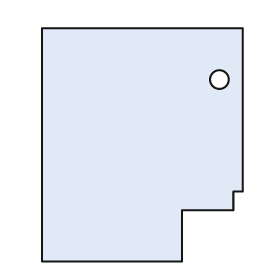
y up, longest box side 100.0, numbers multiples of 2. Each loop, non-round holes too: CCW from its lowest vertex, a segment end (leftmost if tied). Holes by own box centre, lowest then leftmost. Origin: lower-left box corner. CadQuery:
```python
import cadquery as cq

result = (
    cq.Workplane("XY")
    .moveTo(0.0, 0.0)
    .lineTo(60.0, 0.0)
    .lineTo(60.0, 22.0)
    .lineTo(82.0, 22.0)
    .lineTo(82.0, 30.0)
    .lineTo(86.0, 30.0)
    .lineTo(86.0, 100.0)
    .lineTo(0.0, 100.0)
    .close()
    .moveTo(76.0, 78.0)
    .circle(4.0)
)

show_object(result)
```